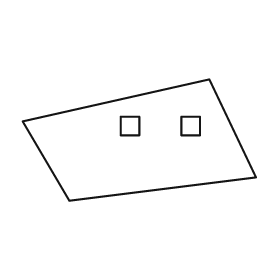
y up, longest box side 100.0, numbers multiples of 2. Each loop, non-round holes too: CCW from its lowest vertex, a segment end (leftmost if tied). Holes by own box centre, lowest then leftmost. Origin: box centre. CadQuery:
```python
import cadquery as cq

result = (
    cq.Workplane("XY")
    .moveTo(-30.0, -26.0)
    .lineTo(50.0, -16.0)
    .lineTo(30.0, 26.0)
    .lineTo(-50.0, 8.0)
    .close()
    .moveTo(-8.0, 2.0)
    .lineTo(0.0, 2.0)
    .lineTo(0.0, 10.0)
    .lineTo(-8.0, 10.0)
    .close()
    .moveTo(18.0, 2.0)
    .lineTo(26.0, 2.0)
    .lineTo(26.0, 10.0)
    .lineTo(18.0, 10.0)
    .close()
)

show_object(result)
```